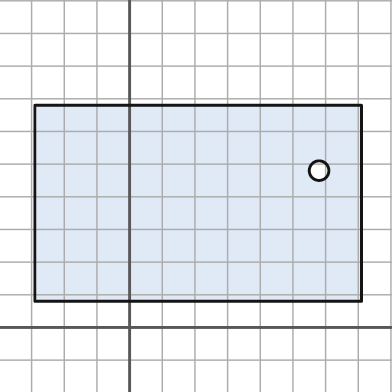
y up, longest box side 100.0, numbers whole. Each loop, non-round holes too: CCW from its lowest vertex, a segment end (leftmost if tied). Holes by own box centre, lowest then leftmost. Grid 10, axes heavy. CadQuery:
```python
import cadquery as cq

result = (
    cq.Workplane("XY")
    .moveTo(-29.0, 8.0)
    .lineTo(71.0, 8.0)
    .lineTo(71.0, 68.0)
    .lineTo(-29.0, 68.0)
    .close()
    .moveTo(58.0, 48.0)
    .circle(3.0)
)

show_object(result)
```